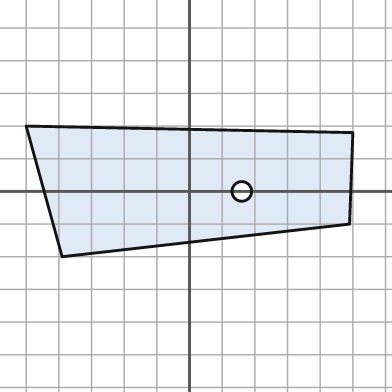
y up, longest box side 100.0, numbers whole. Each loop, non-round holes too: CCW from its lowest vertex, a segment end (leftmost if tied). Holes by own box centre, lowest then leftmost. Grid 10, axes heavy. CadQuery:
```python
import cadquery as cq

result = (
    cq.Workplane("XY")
    .moveTo(-39.0, -20.0)
    .lineTo(49.0, -10.0)
    .lineTo(50.0, 18.0)
    .lineTo(-50.0, 20.0)
    .close()
    .moveTo(16.0, 0.0)
    .circle(3.0)
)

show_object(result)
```